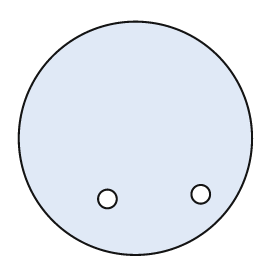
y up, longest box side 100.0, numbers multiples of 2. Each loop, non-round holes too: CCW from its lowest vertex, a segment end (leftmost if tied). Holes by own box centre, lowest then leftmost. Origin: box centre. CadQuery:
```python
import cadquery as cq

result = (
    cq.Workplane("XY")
    .moveTo(0.0, 0.0)
    .circle(50.0)
    .moveTo(-12.0, -26.0)
    .circle(4.0)
    .moveTo(28.0, -24.0)
    .circle(4.0)
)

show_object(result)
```